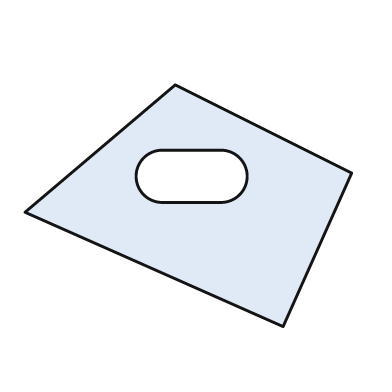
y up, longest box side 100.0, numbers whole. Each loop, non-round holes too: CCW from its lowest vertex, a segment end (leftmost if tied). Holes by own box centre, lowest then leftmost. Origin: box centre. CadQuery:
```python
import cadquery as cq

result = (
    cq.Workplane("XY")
    .moveTo(29.0, -37.0)
    .lineTo(50.0, 10.0)
    .lineTo(-4.0, 37.0)
    .lineTo(-50.0, -2.0)
    .close()
    .moveTo(-8.0, 1.0)
    .lineTo(10.0, 1.0)
    .threePointArc((18.0, 9.0), (10.0, 17.0))
    .lineTo(-8.0, 17.0)
    .threePointArc((-16.0, 9.0), (-8.0, 1.0))
    .close()
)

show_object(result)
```